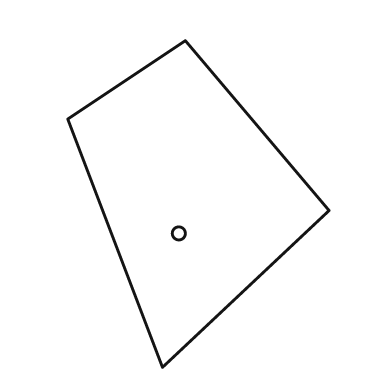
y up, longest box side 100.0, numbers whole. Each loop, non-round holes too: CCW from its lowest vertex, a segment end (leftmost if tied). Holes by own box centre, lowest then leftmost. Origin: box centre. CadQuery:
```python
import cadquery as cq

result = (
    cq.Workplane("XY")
    .moveTo(-11.0, -50.0)
    .lineTo(40.0, -2.0)
    .lineTo(-4.0, 50.0)
    .lineTo(-40.0, 26.0)
    .close()
    .moveTo(-6.0, -9.0)
    .circle(2.0)
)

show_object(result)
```